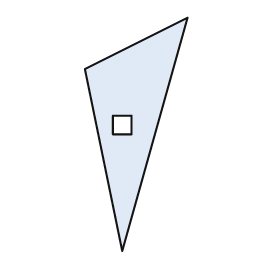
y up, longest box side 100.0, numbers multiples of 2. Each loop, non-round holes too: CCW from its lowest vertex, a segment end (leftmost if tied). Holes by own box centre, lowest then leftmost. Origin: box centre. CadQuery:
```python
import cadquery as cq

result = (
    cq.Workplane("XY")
    .moveTo(-6.0, -50.0)
    .lineTo(22.0, 50.0)
    .lineTo(-22.0, 28.0)
    .close()
    .moveTo(-10.0, 0.0)
    .lineTo(-2.0, 0.0)
    .lineTo(-2.0, 8.0)
    .lineTo(-10.0, 8.0)
    .close()
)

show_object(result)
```